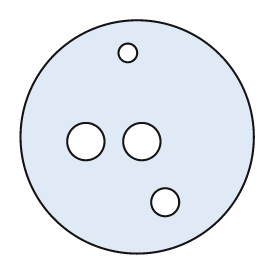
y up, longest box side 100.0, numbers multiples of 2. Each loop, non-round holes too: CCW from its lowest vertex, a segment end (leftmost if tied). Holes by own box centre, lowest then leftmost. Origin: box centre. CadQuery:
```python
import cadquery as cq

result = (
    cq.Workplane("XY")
    .moveTo(0.0, 0.0)
    .circle(50.0)
    .moveTo(12.0, -28.0)
    .circle(6.0)
    .moveTo(-22.0, -2.0)
    .circle(8.0)
    .moveTo(2.0, -2.0)
    .circle(8.0)
    .moveTo(-4.0, 36.0)
    .circle(4.0)
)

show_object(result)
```